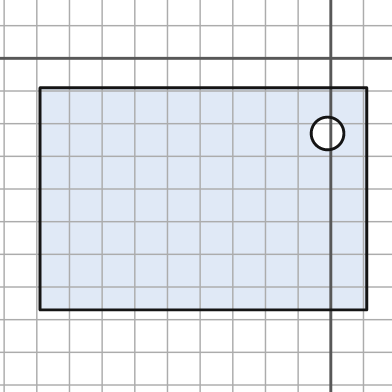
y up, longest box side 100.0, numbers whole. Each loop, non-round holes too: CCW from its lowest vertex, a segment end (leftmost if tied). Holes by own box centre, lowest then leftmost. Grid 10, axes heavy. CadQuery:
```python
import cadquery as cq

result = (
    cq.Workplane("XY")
    .moveTo(-89.0, -77.0)
    .lineTo(11.0, -77.0)
    .lineTo(11.0, -9.0)
    .lineTo(-89.0, -9.0)
    .close()
    .moveTo(-1.0, -23.0)
    .circle(5.0)
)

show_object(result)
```